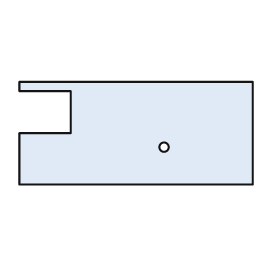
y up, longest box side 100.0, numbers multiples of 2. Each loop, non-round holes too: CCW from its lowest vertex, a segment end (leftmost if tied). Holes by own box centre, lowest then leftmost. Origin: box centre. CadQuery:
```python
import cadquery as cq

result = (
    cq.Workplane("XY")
    .moveTo(-50.0, -22.0)
    .lineTo(50.0, -22.0)
    .lineTo(50.0, 22.0)
    .lineTo(-50.0, 22.0)
    .lineTo(-50.0, 18.0)
    .lineTo(-28.0, 18.0)
    .lineTo(-28.0, 0.0)
    .lineTo(-50.0, 0.0)
    .close()
    .moveTo(12.0, -6.0)
    .circle(2.0)
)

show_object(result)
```